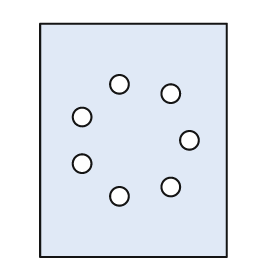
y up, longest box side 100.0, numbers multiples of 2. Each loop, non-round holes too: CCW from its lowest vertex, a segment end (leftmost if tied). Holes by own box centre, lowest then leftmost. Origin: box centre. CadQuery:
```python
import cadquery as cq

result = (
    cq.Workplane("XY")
    .moveTo(-40.0, -50.0)
    .lineTo(40.0, -50.0)
    .lineTo(40.0, 50.0)
    .lineTo(-40.0, 50.0)
    .close()
    .moveTo(-6.0, -24.0)
    .circle(4.0)
    .moveTo(16.0, -20.0)
    .circle(4.0)
    .moveTo(-22.0, -10.0)
    .circle(4.0)
    .moveTo(24.0, 0.0)
    .circle(4.0)
    .moveTo(-22.0, 10.0)
    .circle(4.0)
    .moveTo(16.0, 20.0)
    .circle(4.0)
    .moveTo(-6.0, 24.0)
    .circle(4.0)
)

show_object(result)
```